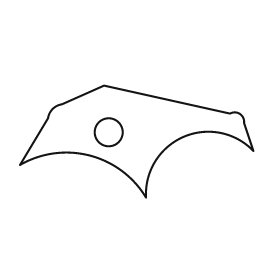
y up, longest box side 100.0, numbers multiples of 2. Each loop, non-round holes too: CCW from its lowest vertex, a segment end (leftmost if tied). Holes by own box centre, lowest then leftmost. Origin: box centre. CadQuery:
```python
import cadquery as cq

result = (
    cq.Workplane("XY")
    .moveTo(4.0, -24.0)
    .threePointArc((20.0, 2.0), (50.0, -4.0))
    .lineTo(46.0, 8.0)
    .threePointArc((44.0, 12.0), (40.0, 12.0))
    .lineTo(-14.0, 24.0)
    .lineTo(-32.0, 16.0)
    .threePointArc((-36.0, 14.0), (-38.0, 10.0))
    .lineTo(-50.0, -10.0)
    .threePointArc((-20.0, -6.0), (4.0, -24.0))
    .close()
    .moveTo(-12.0, 4.0)
    .circle(6.0)
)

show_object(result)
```